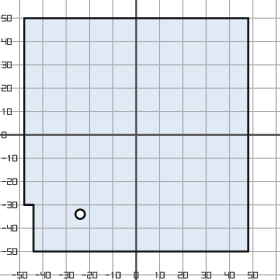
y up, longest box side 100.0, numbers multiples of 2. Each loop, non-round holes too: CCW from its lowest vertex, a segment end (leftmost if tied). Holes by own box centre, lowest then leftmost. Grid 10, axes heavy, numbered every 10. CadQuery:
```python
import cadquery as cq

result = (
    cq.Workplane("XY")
    .moveTo(-44.0, -50.0)
    .lineTo(48.0, -50.0)
    .lineTo(48.0, 50.0)
    .lineTo(-48.0, 50.0)
    .lineTo(-48.0, -30.0)
    .lineTo(-44.0, -30.0)
    .close()
    .moveTo(-24.0, -34.0)
    .circle(2.0)
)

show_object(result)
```